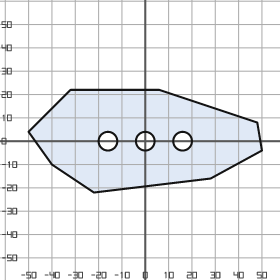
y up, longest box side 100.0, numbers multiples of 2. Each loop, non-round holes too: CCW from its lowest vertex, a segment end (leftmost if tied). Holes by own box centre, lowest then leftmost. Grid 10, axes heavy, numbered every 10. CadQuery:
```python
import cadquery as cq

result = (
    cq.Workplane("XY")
    .moveTo(-22.0, -22.0)
    .lineTo(28.0, -16.0)
    .lineTo(50.0, -4.0)
    .lineTo(48.0, 8.0)
    .lineTo(6.0, 22.0)
    .lineTo(-32.0, 22.0)
    .lineTo(-50.0, 4.0)
    .lineTo(-40.0, -10.0)
    .close()
    .moveTo(-16.0, 0.0)
    .circle(4.0)
    .moveTo(0.0, 0.0)
    .circle(4.0)
    .moveTo(16.0, 0.0)
    .circle(4.0)
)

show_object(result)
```